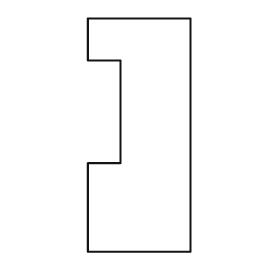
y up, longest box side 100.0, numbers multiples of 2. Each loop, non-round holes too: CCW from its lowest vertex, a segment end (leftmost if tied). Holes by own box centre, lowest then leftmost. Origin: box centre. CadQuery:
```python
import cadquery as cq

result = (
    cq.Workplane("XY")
    .moveTo(-22.0, -50.0)
    .lineTo(22.0, -50.0)
    .lineTo(22.0, 50.0)
    .lineTo(-22.0, 50.0)
    .lineTo(-22.0, 32.0)
    .lineTo(-8.0, 32.0)
    .lineTo(-8.0, -12.0)
    .lineTo(-22.0, -12.0)
    .close()
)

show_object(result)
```